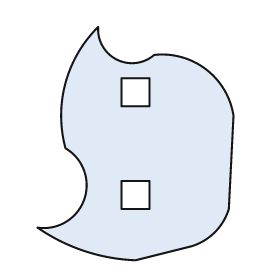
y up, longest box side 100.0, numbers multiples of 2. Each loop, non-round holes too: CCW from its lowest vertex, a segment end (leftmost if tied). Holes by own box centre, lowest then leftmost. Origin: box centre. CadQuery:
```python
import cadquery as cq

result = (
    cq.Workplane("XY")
    .moveTo(0.0, -50.0)
    .lineTo(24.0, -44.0)
    .threePointArc((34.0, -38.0), (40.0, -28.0))
    .lineTo(42.0, 12.0)
    .threePointArc((30.0, 32.0), (8.0, 38.0))
    .threePointArc((-8.0, 36.0), (-16.0, 50.0))
    .threePointArc((-30.0, 26.0), (-30.0, -2.0))
    .threePointArc((-22.0, -24.0), (-42.0, -36.0))
    .threePointArc((-22.0, -46.0), (0.0, -50.0))
    .close()
    .moveTo(-6.0, -28.0)
    .lineTo(6.0, -28.0)
    .lineTo(6.0, -16.0)
    .lineTo(-6.0, -16.0)
    .close()
    .moveTo(-6.0, 16.0)
    .lineTo(6.0, 16.0)
    .lineTo(6.0, 28.0)
    .lineTo(-6.0, 28.0)
    .close()
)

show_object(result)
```